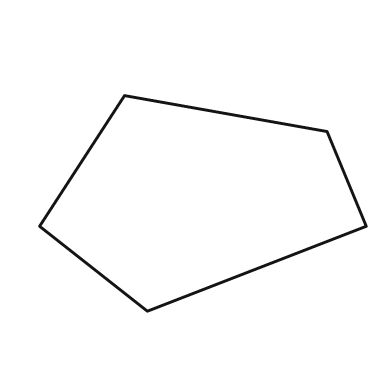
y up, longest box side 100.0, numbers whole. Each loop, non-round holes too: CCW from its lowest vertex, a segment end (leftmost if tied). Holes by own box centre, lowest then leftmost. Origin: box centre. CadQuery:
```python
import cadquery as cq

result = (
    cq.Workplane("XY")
    .moveTo(-17.0, -33.0)
    .lineTo(50.0, -7.0)
    .lineTo(38.0, 22.0)
    .lineTo(-24.0, 33.0)
    .lineTo(-50.0, -7.0)
    .close()
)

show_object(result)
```